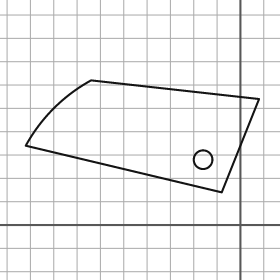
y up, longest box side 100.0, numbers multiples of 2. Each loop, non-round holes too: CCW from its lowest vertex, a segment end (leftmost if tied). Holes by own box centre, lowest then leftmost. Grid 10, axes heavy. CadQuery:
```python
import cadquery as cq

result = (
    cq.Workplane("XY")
    .moveTo(-8.0, 14.0)
    .lineTo(8.0, 54.0)
    .lineTo(-64.0, 62.0)
    .threePointArc((-80.0, 50.0), (-92.0, 34.0))
    .close()
    .moveTo(-16.0, 28.0)
    .circle(4.0)
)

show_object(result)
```